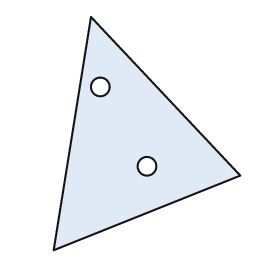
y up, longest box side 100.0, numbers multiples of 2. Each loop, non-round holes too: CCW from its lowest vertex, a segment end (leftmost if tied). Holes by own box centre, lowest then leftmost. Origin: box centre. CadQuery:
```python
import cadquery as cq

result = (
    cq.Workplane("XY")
    .moveTo(-40.0, -50.0)
    .lineTo(40.0, -18.0)
    .lineTo(-24.0, 50.0)
    .close()
    .moveTo(0.0, -14.0)
    .circle(4.0)
    .moveTo(-20.0, 20.0)
    .circle(4.0)
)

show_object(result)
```